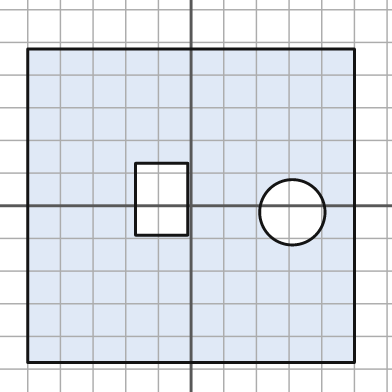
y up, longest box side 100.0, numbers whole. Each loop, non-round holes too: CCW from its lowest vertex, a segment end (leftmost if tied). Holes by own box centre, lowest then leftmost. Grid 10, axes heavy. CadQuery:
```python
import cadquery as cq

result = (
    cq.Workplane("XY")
    .moveTo(-50.0, -48.0)
    .lineTo(50.0, -48.0)
    .lineTo(50.0, 48.0)
    .lineTo(-50.0, 48.0)
    .close()
    .moveTo(31.0, -2.0)
    .circle(10.0)
    .moveTo(-17.0, -9.0)
    .lineTo(-1.0, -9.0)
    .lineTo(-1.0, 13.0)
    .lineTo(-17.0, 13.0)
    .close()
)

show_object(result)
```